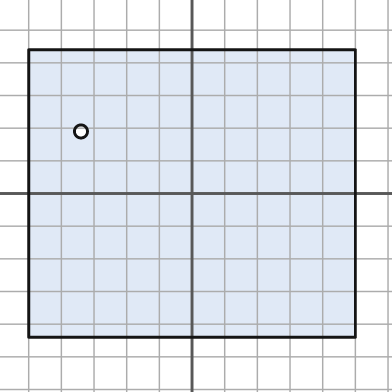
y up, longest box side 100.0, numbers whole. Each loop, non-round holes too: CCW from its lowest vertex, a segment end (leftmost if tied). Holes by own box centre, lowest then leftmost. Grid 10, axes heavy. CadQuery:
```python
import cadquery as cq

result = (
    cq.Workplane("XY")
    .moveTo(-50.0, -44.0)
    .lineTo(50.0, -44.0)
    .lineTo(50.0, 44.0)
    .lineTo(-50.0, 44.0)
    .close()
    .moveTo(-34.0, 19.0)
    .circle(2.0)
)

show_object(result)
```